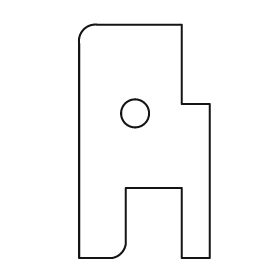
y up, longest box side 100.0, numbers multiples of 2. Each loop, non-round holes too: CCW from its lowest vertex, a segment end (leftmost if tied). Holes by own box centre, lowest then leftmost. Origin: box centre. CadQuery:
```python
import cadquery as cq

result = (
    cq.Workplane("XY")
    .moveTo(-28.0, -50.0)
    .lineTo(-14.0, -50.0)
    .threePointArc((-10.0, -48.0), (-8.0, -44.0))
    .lineTo(-8.0, -20.0)
    .lineTo(16.0, -20.0)
    .lineTo(16.0, -50.0)
    .lineTo(28.0, -50.0)
    .lineTo(28.0, 16.0)
    .lineTo(16.0, 16.0)
    .lineTo(16.0, 50.0)
    .lineTo(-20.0, 50.0)
    .threePointArc((-26.0, 48.0), (-28.0, 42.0))
    .close()
    .moveTo(-4.0, 12.0)
    .circle(6.0)
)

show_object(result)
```